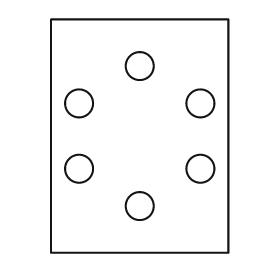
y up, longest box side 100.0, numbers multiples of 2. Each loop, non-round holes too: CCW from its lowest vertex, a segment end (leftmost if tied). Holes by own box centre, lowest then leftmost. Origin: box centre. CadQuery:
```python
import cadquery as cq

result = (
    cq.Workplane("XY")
    .moveTo(-38.0, -50.0)
    .lineTo(38.0, -50.0)
    .lineTo(38.0, 50.0)
    .lineTo(-38.0, 50.0)
    .close()
    .moveTo(0.0, -30.0)
    .circle(6.0)
    .moveTo(-26.0, -14.0)
    .circle(6.0)
    .moveTo(26.0, -14.0)
    .circle(6.0)
    .moveTo(-26.0, 14.0)
    .circle(6.0)
    .moveTo(26.0, 14.0)
    .circle(6.0)
    .moveTo(0.0, 30.0)
    .circle(6.0)
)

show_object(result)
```